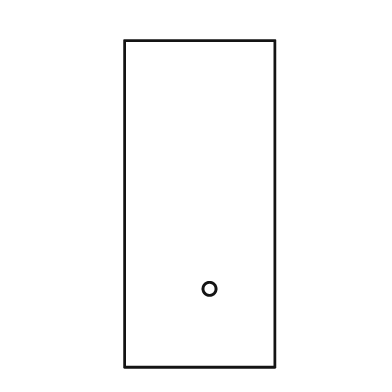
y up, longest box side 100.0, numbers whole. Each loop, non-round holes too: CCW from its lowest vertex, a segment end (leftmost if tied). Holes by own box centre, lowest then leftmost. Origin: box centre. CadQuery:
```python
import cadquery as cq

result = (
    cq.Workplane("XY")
    .moveTo(-23.0, -50.0)
    .lineTo(23.0, -50.0)
    .lineTo(23.0, 50.0)
    .lineTo(-23.0, 50.0)
    .close()
    .moveTo(3.0, -26.0)
    .circle(2.0)
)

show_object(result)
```